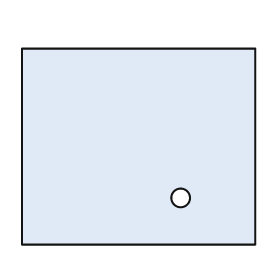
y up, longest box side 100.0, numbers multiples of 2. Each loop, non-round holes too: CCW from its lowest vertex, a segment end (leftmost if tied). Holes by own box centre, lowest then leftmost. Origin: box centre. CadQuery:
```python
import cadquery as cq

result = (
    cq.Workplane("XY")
    .moveTo(-50.0, -42.0)
    .lineTo(50.0, -42.0)
    .lineTo(50.0, 42.0)
    .lineTo(-50.0, 42.0)
    .close()
    .moveTo(18.0, -22.0)
    .circle(4.0)
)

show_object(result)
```